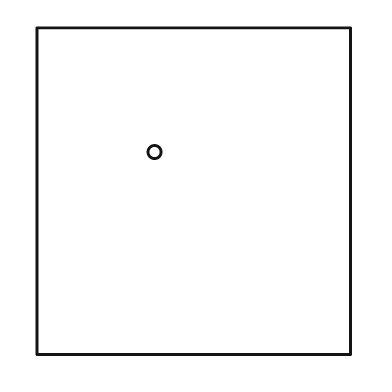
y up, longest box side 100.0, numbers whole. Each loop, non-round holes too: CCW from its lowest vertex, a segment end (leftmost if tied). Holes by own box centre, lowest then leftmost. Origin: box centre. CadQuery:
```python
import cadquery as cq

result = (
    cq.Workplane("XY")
    .moveTo(-48.0, -50.0)
    .lineTo(48.0, -50.0)
    .lineTo(48.0, 50.0)
    .lineTo(-48.0, 50.0)
    .close()
    .moveTo(-12.0, 12.0)
    .circle(2.0)
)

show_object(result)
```